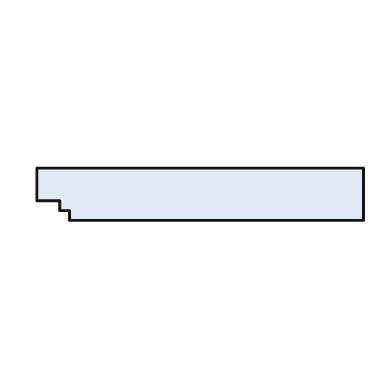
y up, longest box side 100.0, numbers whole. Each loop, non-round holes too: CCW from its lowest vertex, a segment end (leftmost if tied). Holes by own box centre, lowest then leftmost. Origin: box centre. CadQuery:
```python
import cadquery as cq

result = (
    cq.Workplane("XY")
    .moveTo(-40.0, -8.0)
    .lineTo(50.0, -8.0)
    .lineTo(50.0, 8.0)
    .lineTo(-50.0, 8.0)
    .lineTo(-50.0, -2.0)
    .lineTo(-43.0, -2.0)
    .lineTo(-43.0, -5.0)
    .lineTo(-40.0, -5.0)
    .close()
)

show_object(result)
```